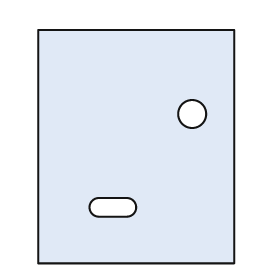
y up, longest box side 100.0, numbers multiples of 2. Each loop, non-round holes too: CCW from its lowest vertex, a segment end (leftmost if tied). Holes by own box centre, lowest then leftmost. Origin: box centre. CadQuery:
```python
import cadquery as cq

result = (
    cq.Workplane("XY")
    .moveTo(-42.0, -50.0)
    .lineTo(42.0, -50.0)
    .lineTo(42.0, 50.0)
    .lineTo(-42.0, 50.0)
    .close()
    .moveTo(-16.0, -30.0)
    .lineTo(-4.0, -30.0)
    .threePointArc((0.0, -26.0), (-4.0, -22.0))
    .lineTo(-16.0, -22.0)
    .threePointArc((-20.0, -26.0), (-16.0, -30.0))
    .close()
    .moveTo(24.0, 14.0)
    .circle(6.0)
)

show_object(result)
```